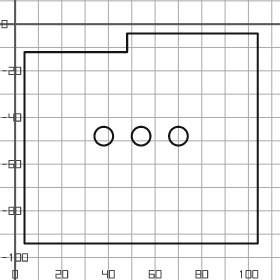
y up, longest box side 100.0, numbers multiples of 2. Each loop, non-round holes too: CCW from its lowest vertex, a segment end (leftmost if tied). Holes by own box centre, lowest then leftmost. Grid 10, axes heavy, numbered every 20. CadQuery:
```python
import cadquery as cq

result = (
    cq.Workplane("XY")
    .moveTo(4.0, -94.0)
    .lineTo(104.0, -94.0)
    .lineTo(104.0, -4.0)
    .lineTo(48.0, -4.0)
    .lineTo(48.0, -12.0)
    .lineTo(4.0, -12.0)
    .close()
    .moveTo(38.0, -48.0)
    .circle(4.0)
    .moveTo(54.0, -48.0)
    .circle(4.0)
    .moveTo(70.0, -48.0)
    .circle(4.0)
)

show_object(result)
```